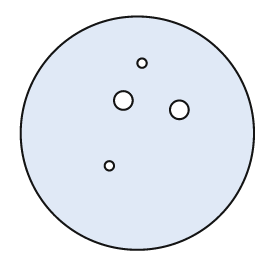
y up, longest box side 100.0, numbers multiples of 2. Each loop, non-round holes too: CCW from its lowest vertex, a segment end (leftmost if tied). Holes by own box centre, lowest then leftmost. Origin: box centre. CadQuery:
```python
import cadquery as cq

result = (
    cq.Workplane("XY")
    .moveTo(0.0, 0.0)
    .circle(50.0)
    .moveTo(-12.0, -14.0)
    .circle(2.0)
    .moveTo(18.0, 10.0)
    .circle(4.0)
    .moveTo(-6.0, 14.0)
    .circle(4.0)
    .moveTo(2.0, 30.0)
    .circle(2.0)
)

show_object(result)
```